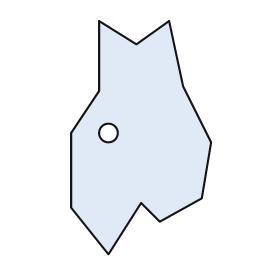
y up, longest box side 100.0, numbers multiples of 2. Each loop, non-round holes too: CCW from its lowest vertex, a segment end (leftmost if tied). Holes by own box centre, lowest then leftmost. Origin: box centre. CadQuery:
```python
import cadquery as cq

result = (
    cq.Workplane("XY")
    .moveTo(-14.0, -50.0)
    .lineTo(0.0, -28.0)
    .lineTo(8.0, -36.0)
    .lineTo(26.0, -26.0)
    .lineTo(30.0, -2.0)
    .lineTo(18.0, 22.0)
    .lineTo(12.0, 50.0)
    .lineTo(-2.0, 40.0)
    .lineTo(-18.0, 50.0)
    .lineTo(-18.0, 20.0)
    .lineTo(-30.0, 2.0)
    .lineTo(-30.0, -30.0)
    .close()
    .moveTo(-14.0, 2.0)
    .circle(4.0)
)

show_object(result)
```